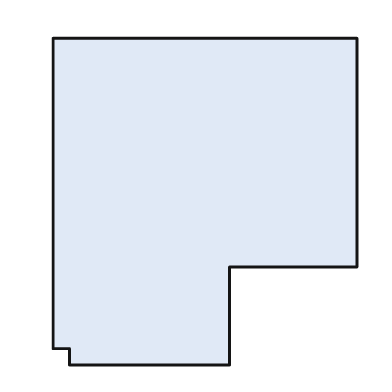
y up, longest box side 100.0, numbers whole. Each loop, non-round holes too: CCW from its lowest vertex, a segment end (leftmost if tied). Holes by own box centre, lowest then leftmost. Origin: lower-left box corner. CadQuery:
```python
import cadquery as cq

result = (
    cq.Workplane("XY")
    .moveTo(5.0, 0.0)
    .lineTo(54.0, 0.0)
    .lineTo(54.0, 30.0)
    .lineTo(93.0, 30.0)
    .lineTo(93.0, 100.0)
    .lineTo(0.0, 100.0)
    .lineTo(0.0, 5.0)
    .lineTo(5.0, 5.0)
    .close()
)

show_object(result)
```